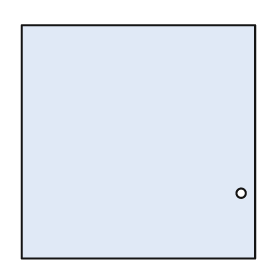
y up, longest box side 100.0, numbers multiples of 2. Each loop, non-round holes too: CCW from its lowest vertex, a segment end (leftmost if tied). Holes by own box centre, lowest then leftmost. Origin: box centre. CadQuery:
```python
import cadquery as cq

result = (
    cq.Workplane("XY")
    .moveTo(-50.0, -50.0)
    .lineTo(50.0, -50.0)
    .lineTo(50.0, 50.0)
    .lineTo(-50.0, 50.0)
    .close()
    .moveTo(44.0, -22.0)
    .circle(2.0)
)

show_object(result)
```